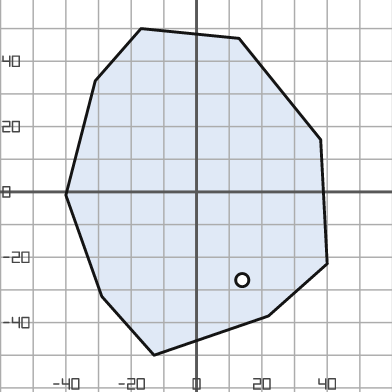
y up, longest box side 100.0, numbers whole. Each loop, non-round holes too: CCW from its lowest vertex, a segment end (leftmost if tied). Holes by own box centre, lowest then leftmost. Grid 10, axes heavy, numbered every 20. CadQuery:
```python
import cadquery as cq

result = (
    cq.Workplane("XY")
    .moveTo(-13.0, -50.0)
    .lineTo(22.0, -38.0)
    .lineTo(40.0, -22.0)
    .lineTo(38.0, 16.0)
    .lineTo(13.0, 47.0)
    .lineTo(-17.0, 50.0)
    .lineTo(-31.0, 34.0)
    .lineTo(-40.0, -1.0)
    .lineTo(-29.0, -32.0)
    .close()
    .moveTo(14.0, -27.0)
    .circle(2.0)
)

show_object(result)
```